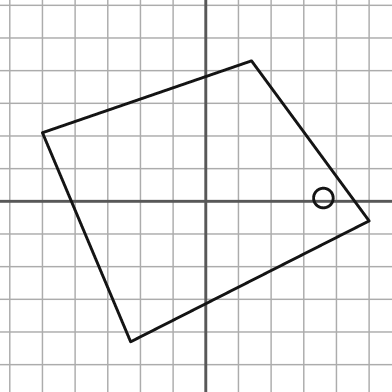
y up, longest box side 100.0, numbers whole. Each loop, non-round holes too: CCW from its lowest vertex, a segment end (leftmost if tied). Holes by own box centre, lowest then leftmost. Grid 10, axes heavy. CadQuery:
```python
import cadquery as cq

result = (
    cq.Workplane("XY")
    .moveTo(-23.0, -43.0)
    .lineTo(50.0, -6.0)
    .lineTo(14.0, 43.0)
    .lineTo(-50.0, 21.0)
    .close()
    .moveTo(36.0, 1.0)
    .circle(3.0)
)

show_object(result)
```